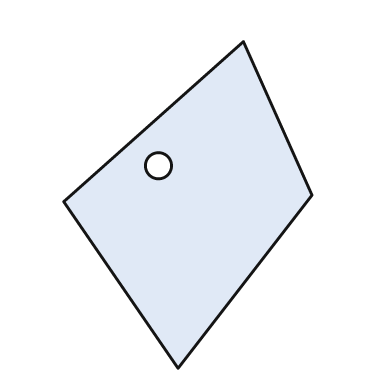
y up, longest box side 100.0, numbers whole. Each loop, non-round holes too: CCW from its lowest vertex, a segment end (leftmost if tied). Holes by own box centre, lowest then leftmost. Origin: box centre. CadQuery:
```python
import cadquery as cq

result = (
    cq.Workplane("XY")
    .moveTo(-3.0, -50.0)
    .lineTo(38.0, 3.0)
    .lineTo(17.0, 50.0)
    .lineTo(-38.0, 1.0)
    .close()
    .moveTo(-9.0, 12.0)
    .circle(4.0)
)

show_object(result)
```